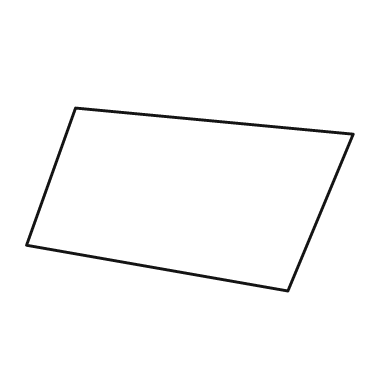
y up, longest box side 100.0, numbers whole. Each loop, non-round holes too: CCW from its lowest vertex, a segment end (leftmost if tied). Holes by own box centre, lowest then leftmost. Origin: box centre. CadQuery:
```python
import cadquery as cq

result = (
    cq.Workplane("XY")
    .moveTo(30.0, -28.0)
    .lineTo(50.0, 20.0)
    .lineTo(-35.0, 28.0)
    .lineTo(-50.0, -14.0)
    .close()
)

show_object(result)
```